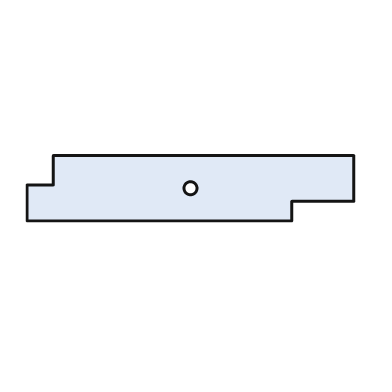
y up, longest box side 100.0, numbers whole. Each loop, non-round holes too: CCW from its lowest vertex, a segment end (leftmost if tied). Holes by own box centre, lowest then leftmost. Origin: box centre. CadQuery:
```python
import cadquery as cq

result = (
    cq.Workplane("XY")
    .moveTo(-50.0, -10.0)
    .lineTo(31.0, -10.0)
    .lineTo(31.0, -4.0)
    .lineTo(50.0, -4.0)
    .lineTo(50.0, 10.0)
    .lineTo(-42.0, 10.0)
    .lineTo(-42.0, 1.0)
    .lineTo(-50.0, 1.0)
    .close()
    .moveTo(0.0, 0.0)
    .circle(2.0)
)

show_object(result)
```